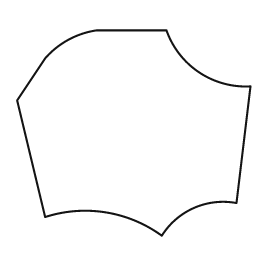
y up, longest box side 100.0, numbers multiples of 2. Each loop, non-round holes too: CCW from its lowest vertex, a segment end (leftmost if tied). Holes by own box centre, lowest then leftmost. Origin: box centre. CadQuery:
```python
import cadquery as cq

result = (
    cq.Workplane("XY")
    .moveTo(12.0, -44.0)
    .threePointArc((26.0, -32.0), (44.0, -30.0))
    .lineTo(50.0, 20.0)
    .threePointArc((28.0, 26.0), (14.0, 44.0))
    .lineTo(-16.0, 44.0)
    .threePointArc((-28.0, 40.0), (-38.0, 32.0))
    .lineTo(-50.0, 14.0)
    .lineTo(-38.0, -36.0)
    .threePointArc((-12.0, -34.0), (12.0, -44.0))
    .close()
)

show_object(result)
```